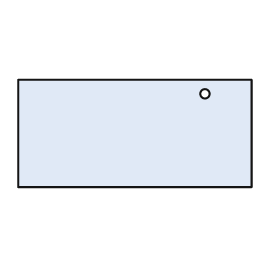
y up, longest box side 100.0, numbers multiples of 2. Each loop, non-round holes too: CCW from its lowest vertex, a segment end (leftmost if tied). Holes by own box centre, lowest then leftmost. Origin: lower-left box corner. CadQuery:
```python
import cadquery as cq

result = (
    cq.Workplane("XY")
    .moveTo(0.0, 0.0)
    .lineTo(100.0, 0.0)
    .lineTo(100.0, 46.0)
    .lineTo(0.0, 46.0)
    .close()
    .moveTo(80.0, 40.0)
    .circle(2.0)
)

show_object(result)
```